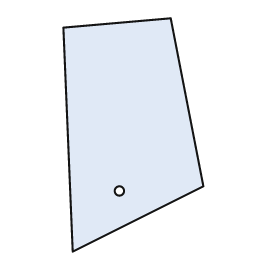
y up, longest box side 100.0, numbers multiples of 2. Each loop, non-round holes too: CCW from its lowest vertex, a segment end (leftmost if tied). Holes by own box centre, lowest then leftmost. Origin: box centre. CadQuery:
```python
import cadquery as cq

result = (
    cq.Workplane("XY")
    .moveTo(-26.0, -50.0)
    .lineTo(30.0, -22.0)
    .lineTo(16.0, 50.0)
    .lineTo(-30.0, 46.0)
    .close()
    .moveTo(-6.0, -24.0)
    .circle(2.0)
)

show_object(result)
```